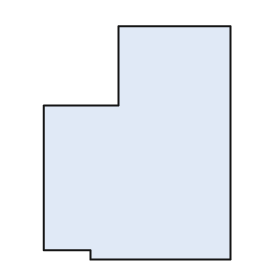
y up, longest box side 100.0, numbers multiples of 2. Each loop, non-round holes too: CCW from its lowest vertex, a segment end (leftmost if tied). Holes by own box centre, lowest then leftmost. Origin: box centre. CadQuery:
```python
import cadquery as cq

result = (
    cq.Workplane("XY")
    .moveTo(-20.0, -50.0)
    .lineTo(40.0, -50.0)
    .lineTo(40.0, 50.0)
    .lineTo(-8.0, 50.0)
    .lineTo(-8.0, 16.0)
    .lineTo(-40.0, 16.0)
    .lineTo(-40.0, -46.0)
    .lineTo(-20.0, -46.0)
    .close()
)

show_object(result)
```